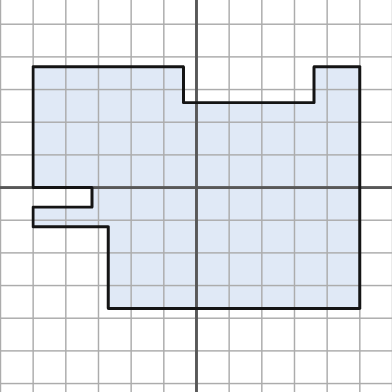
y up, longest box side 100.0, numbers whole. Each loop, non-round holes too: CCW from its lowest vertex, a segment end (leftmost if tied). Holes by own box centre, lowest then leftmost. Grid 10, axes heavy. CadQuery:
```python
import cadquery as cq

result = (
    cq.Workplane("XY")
    .moveTo(-27.0, -37.0)
    .lineTo(50.0, -37.0)
    .lineTo(50.0, 37.0)
    .lineTo(36.0, 37.0)
    .lineTo(36.0, 26.0)
    .lineTo(-4.0, 26.0)
    .lineTo(-4.0, 37.0)
    .lineTo(-50.0, 37.0)
    .lineTo(-50.0, 0.0)
    .lineTo(-32.0, 0.0)
    .lineTo(-32.0, -6.0)
    .lineTo(-50.0, -6.0)
    .lineTo(-50.0, -12.0)
    .lineTo(-27.0, -12.0)
    .close()
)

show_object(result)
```